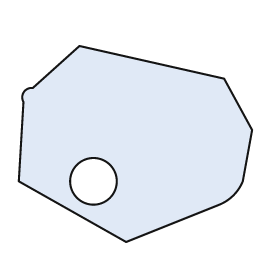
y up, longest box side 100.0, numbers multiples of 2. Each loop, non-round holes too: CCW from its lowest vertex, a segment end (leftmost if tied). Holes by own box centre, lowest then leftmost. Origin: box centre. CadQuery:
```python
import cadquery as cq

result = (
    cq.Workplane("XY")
    .moveTo(-4.0, -42.0)
    .lineTo(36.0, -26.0)
    .threePointArc((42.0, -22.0), (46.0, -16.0))
    .lineTo(50.0, 6.0)
    .lineTo(38.0, 28.0)
    .lineTo(-24.0, 42.0)
    .lineTo(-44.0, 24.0)
    .threePointArc((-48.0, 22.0), (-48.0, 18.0))
    .lineTo(-50.0, -16.0)
    .close()
    .moveTo(-18.0, -16.0)
    .circle(10.0)
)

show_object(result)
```